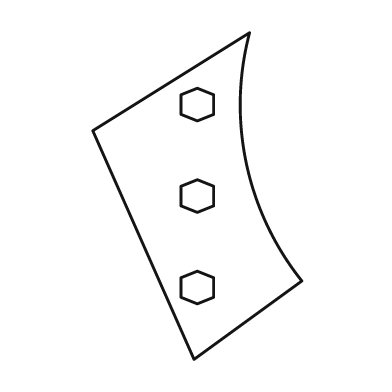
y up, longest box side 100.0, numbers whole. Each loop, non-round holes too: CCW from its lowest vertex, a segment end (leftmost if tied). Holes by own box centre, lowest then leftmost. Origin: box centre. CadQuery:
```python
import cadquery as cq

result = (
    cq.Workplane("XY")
    .moveTo(-1.0, -50.0)
    .lineTo(32.0, -26.0)
    .threePointArc((15.0, 10.0), (16.0, 50.0))
    .lineTo(-32.0, 20.0)
    .close()
    .moveTo(0.0, -33.0)
    .lineTo(5.0, -31.0)
    .lineTo(5.0, -25.0)
    .lineTo(0.0, -23.0)
    .lineTo(-5.0, -25.0)
    .lineTo(-5.0, -31.0)
    .close()
    .moveTo(0.0, -5.0)
    .lineTo(5.0, -3.0)
    .lineTo(5.0, 3.0)
    .lineTo(0.0, 5.0)
    .lineTo(-5.0, 3.0)
    .lineTo(-5.0, -3.0)
    .close()
    .moveTo(0.0, 23.0)
    .lineTo(5.0, 25.0)
    .lineTo(5.0, 31.0)
    .lineTo(0.0, 33.0)
    .lineTo(-5.0, 31.0)
    .lineTo(-5.0, 25.0)
    .close()
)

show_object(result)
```